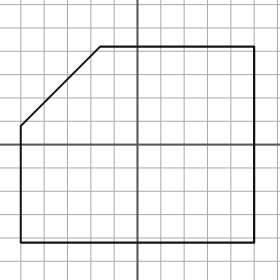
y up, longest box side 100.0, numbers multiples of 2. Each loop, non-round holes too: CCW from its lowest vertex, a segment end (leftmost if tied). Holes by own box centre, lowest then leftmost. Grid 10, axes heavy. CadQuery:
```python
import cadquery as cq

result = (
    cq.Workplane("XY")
    .moveTo(-50.0, -42.0)
    .lineTo(50.0, -42.0)
    .lineTo(50.0, 42.0)
    .lineTo(-16.0, 42.0)
    .lineTo(-50.0, 8.0)
    .close()
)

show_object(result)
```